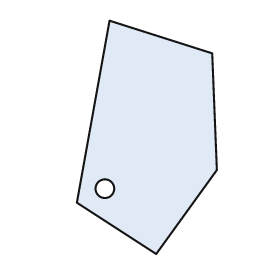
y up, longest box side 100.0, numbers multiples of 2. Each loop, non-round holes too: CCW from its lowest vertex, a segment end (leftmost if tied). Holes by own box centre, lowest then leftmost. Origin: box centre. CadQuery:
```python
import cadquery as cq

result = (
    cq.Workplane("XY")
    .moveTo(4.0, -50.0)
    .lineTo(30.0, -14.0)
    .lineTo(28.0, 36.0)
    .lineTo(-16.0, 50.0)
    .lineTo(-30.0, -28.0)
    .close()
    .moveTo(-18.0, -22.0)
    .circle(4.0)
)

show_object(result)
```